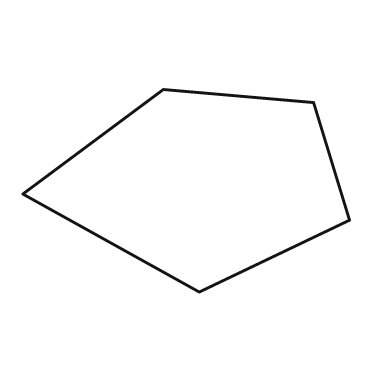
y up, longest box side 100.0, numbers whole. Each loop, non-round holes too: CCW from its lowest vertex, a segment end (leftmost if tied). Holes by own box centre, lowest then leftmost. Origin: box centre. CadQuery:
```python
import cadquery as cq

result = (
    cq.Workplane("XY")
    .moveTo(4.0, -31.0)
    .lineTo(50.0, -9.0)
    .lineTo(39.0, 27.0)
    .lineTo(-7.0, 31.0)
    .lineTo(-50.0, -1.0)
    .close()
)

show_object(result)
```